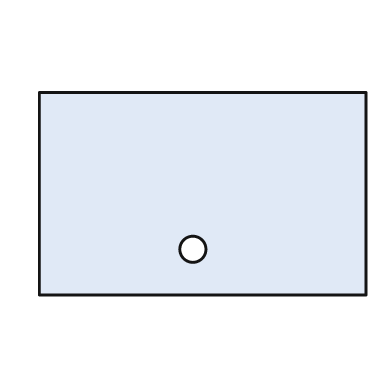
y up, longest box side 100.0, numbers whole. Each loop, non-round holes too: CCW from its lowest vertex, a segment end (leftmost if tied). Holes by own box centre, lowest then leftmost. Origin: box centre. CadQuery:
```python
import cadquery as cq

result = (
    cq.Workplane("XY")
    .moveTo(-50.0, -31.0)
    .lineTo(50.0, -31.0)
    .lineTo(50.0, 31.0)
    .lineTo(-50.0, 31.0)
    .close()
    .moveTo(-3.0, -17.0)
    .circle(4.0)
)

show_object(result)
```